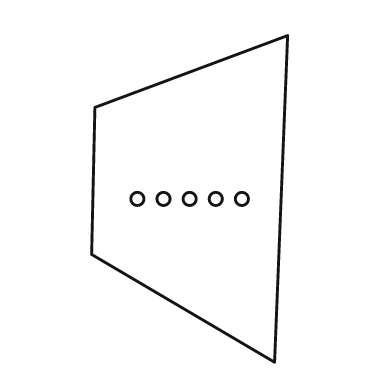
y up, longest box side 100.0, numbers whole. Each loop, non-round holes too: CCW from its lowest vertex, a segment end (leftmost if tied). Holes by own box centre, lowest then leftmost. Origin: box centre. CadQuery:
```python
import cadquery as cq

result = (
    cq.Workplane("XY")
    .moveTo(26.0, -50.0)
    .lineTo(30.0, 50.0)
    .lineTo(-29.0, 28.0)
    .lineTo(-30.0, -17.0)
    .close()
    .moveTo(-16.0, 0.0)
    .circle(2.0)
    .moveTo(-8.0, 0.0)
    .circle(2.0)
    .moveTo(0.0, 0.0)
    .circle(2.0)
    .moveTo(8.0, 0.0)
    .circle(2.0)
    .moveTo(16.0, 0.0)
    .circle(2.0)
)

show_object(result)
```